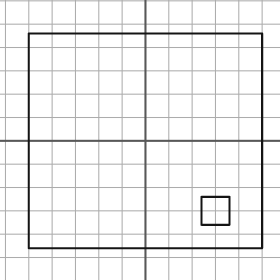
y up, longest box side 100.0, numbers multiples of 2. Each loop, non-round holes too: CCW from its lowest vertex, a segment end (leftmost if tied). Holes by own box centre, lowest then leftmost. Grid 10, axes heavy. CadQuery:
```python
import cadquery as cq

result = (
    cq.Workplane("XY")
    .moveTo(-50.0, -46.0)
    .lineTo(50.0, -46.0)
    .lineTo(50.0, 46.0)
    .lineTo(-50.0, 46.0)
    .close()
    .moveTo(24.0, -36.0)
    .lineTo(36.0, -36.0)
    .lineTo(36.0, -24.0)
    .lineTo(24.0, -24.0)
    .close()
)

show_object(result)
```